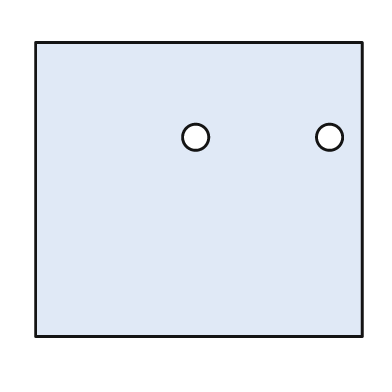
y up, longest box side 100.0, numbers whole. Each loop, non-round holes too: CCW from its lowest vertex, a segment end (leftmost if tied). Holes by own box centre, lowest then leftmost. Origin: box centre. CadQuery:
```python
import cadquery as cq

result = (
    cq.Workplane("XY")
    .moveTo(-50.0, -45.0)
    .lineTo(50.0, -45.0)
    .lineTo(50.0, 45.0)
    .lineTo(-50.0, 45.0)
    .close()
    .moveTo(-1.0, 16.0)
    .circle(4.0)
    .moveTo(40.0, 16.0)
    .circle(4.0)
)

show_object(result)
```